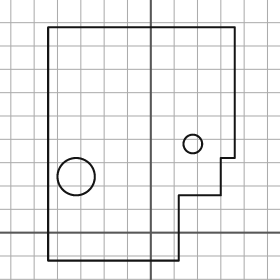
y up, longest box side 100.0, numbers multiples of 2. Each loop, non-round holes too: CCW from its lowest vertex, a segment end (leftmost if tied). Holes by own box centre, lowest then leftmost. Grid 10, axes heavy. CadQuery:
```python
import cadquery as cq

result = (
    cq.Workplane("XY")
    .moveTo(-44.0, -12.0)
    .lineTo(12.0, -12.0)
    .lineTo(12.0, 16.0)
    .lineTo(30.0, 16.0)
    .lineTo(30.0, 32.0)
    .lineTo(36.0, 32.0)
    .lineTo(36.0, 88.0)
    .lineTo(-44.0, 88.0)
    .close()
    .moveTo(-32.0, 24.0)
    .circle(8.0)
    .moveTo(18.0, 38.0)
    .circle(4.0)
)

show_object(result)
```